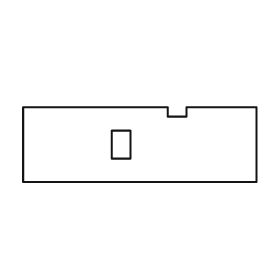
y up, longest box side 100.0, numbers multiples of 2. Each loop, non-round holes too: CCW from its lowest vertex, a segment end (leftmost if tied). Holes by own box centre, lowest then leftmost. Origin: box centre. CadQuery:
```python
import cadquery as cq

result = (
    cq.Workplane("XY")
    .moveTo(-50.0, -16.0)
    .lineTo(50.0, -16.0)
    .lineTo(50.0, 16.0)
    .lineTo(20.0, 16.0)
    .lineTo(20.0, 12.0)
    .lineTo(12.0, 12.0)
    .lineTo(12.0, 16.0)
    .lineTo(-50.0, 16.0)
    .close()
    .moveTo(-12.0, -6.0)
    .lineTo(-4.0, -6.0)
    .lineTo(-4.0, 6.0)
    .lineTo(-12.0, 6.0)
    .close()
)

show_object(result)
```